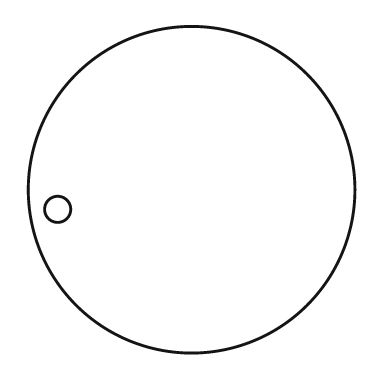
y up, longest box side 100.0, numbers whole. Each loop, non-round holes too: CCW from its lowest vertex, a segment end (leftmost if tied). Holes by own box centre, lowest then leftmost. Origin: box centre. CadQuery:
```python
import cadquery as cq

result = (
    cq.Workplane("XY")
    .moveTo(0.0, 0.0)
    .circle(50.0)
    .moveTo(-41.0, -6.0)
    .circle(4.0)
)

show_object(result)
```